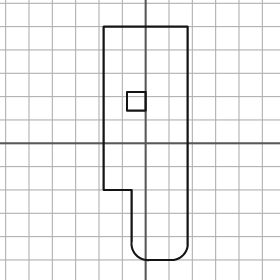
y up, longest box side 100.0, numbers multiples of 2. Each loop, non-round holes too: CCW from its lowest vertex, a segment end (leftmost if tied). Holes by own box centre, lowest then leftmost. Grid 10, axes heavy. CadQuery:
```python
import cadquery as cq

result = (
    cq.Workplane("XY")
    .moveTo(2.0, -50.0)
    .lineTo(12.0, -50.0)
    .threePointArc((16.0, -48.0), (18.0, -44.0))
    .lineTo(18.0, 50.0)
    .lineTo(-18.0, 50.0)
    .lineTo(-18.0, -20.0)
    .lineTo(-6.0, -20.0)
    .lineTo(-6.0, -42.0)
    .threePointArc((-4.0, -48.0), (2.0, -50.0))
    .close()
    .moveTo(-8.0, 14.0)
    .lineTo(0.0, 14.0)
    .lineTo(0.0, 22.0)
    .lineTo(-8.0, 22.0)
    .close()
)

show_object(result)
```